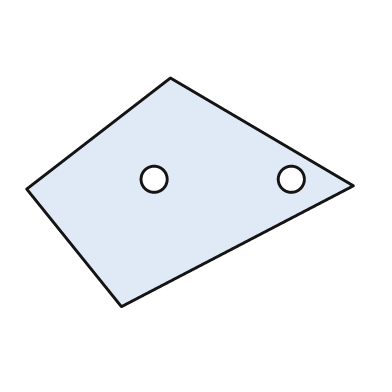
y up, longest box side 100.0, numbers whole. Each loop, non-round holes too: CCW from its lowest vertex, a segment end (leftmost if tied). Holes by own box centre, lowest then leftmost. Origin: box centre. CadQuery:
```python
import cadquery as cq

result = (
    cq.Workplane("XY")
    .moveTo(-21.0, -35.0)
    .lineTo(50.0, 2.0)
    .lineTo(-6.0, 35.0)
    .lineTo(-50.0, 1.0)
    .close()
    .moveTo(-11.0, 4.0)
    .circle(4.0)
    .moveTo(31.0, 4.0)
    .circle(4.0)
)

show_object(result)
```